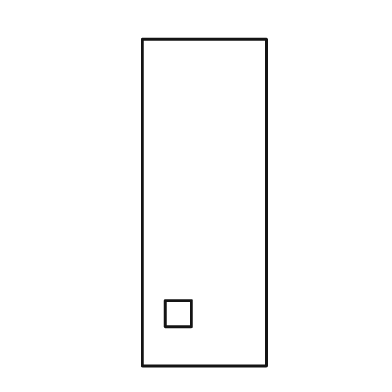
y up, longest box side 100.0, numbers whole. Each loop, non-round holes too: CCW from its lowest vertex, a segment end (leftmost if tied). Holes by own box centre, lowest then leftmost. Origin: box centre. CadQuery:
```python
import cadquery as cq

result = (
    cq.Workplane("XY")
    .moveTo(-19.0, -50.0)
    .lineTo(19.0, -50.0)
    .lineTo(19.0, 50.0)
    .lineTo(-19.0, 50.0)
    .close()
    .moveTo(-12.0, -38.0)
    .lineTo(-4.0, -38.0)
    .lineTo(-4.0, -30.0)
    .lineTo(-12.0, -30.0)
    .close()
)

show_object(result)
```